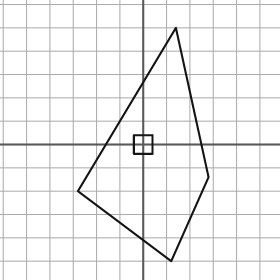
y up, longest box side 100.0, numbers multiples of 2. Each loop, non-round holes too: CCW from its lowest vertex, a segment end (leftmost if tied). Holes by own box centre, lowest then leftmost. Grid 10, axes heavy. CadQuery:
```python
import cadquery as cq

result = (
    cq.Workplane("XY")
    .moveTo(12.0, -50.0)
    .lineTo(28.0, -14.0)
    .lineTo(14.0, 50.0)
    .lineTo(-28.0, -20.0)
    .close()
    .moveTo(-4.0, -4.0)
    .lineTo(4.0, -4.0)
    .lineTo(4.0, 4.0)
    .lineTo(-4.0, 4.0)
    .close()
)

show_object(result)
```